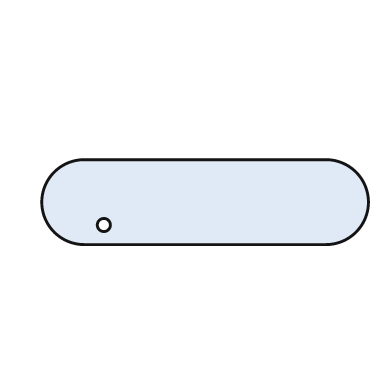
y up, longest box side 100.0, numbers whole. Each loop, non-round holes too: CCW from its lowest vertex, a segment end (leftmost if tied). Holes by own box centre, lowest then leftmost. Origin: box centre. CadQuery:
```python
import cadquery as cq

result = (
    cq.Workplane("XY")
    .moveTo(-37.0, -13.0)
    .lineTo(37.0, -13.0)
    .threePointArc((50.0, 0.0), (37.0, 13.0))
    .lineTo(-37.0, 13.0)
    .threePointArc((-50.0, 0.0), (-37.0, -13.0))
    .close()
    .moveTo(-31.0, -7.0)
    .circle(2.0)
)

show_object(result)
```